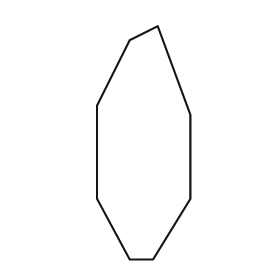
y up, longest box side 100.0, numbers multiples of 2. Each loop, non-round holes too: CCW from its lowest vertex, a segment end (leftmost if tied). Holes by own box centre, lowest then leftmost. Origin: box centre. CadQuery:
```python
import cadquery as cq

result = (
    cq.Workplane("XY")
    .moveTo(-6.0, -50.0)
    .lineTo(4.0, -50.0)
    .lineTo(20.0, -24.0)
    .lineTo(20.0, 12.0)
    .lineTo(6.0, 50.0)
    .lineTo(-6.0, 44.0)
    .lineTo(-20.0, 16.0)
    .lineTo(-20.0, -24.0)
    .close()
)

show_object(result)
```